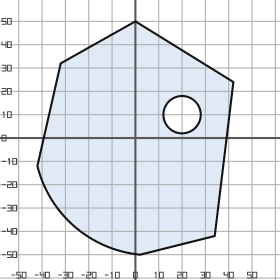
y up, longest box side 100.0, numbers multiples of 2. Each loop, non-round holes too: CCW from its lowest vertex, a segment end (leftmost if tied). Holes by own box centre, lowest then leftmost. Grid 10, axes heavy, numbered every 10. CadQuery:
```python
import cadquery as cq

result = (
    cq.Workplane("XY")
    .moveTo(2.0, -50.0)
    .lineTo(34.0, -42.0)
    .lineTo(42.0, 24.0)
    .lineTo(0.0, 50.0)
    .lineTo(-32.0, 32.0)
    .lineTo(-42.0, -12.0)
    .threePointArc((-26.0, -38.0), (2.0, -50.0))
    .close()
    .moveTo(20.0, 10.0)
    .circle(8.0)
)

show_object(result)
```